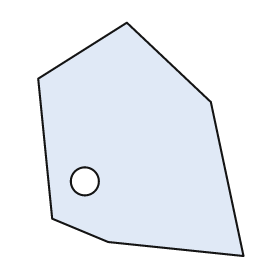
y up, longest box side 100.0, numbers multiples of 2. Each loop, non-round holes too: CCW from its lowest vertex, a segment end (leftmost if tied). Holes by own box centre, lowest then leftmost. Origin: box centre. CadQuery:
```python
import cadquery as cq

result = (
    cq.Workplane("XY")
    .moveTo(44.0, -50.0)
    .lineTo(30.0, 16.0)
    .lineTo(-6.0, 50.0)
    .lineTo(-44.0, 26.0)
    .lineTo(-38.0, -34.0)
    .lineTo(-14.0, -44.0)
    .close()
    .moveTo(-24.0, -18.0)
    .circle(6.0)
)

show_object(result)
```